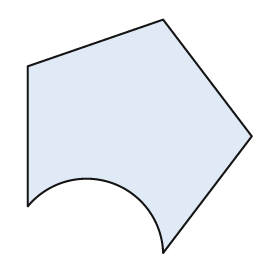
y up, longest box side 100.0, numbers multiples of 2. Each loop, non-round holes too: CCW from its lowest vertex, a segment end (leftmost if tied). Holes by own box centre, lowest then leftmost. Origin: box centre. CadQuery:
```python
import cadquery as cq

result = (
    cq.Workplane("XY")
    .moveTo(10.0, -50.0)
    .lineTo(48.0, 0.0)
    .lineTo(10.0, 50.0)
    .lineTo(-48.0, 30.0)
    .lineTo(-48.0, -30.0)
    .threePointArc((-12.0, -20.0), (10.0, -50.0))
    .close()
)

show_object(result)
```